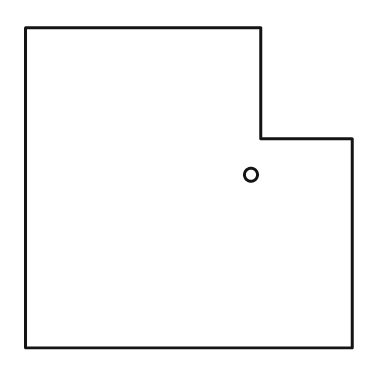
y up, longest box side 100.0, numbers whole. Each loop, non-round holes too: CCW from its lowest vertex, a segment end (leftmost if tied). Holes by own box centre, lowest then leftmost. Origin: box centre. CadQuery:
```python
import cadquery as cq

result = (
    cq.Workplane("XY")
    .moveTo(-50.0, -49.0)
    .lineTo(50.0, -49.0)
    .lineTo(50.0, 15.0)
    .lineTo(22.0, 15.0)
    .lineTo(22.0, 49.0)
    .lineTo(-50.0, 49.0)
    .close()
    .moveTo(19.0, 4.0)
    .circle(2.0)
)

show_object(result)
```